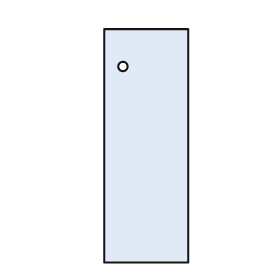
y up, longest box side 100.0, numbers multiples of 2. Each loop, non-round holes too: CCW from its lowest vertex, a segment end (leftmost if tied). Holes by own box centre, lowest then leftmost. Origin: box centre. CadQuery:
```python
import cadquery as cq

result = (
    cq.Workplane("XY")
    .moveTo(-18.0, -50.0)
    .lineTo(18.0, -50.0)
    .lineTo(18.0, 50.0)
    .lineTo(-18.0, 50.0)
    .close()
    .moveTo(-10.0, 34.0)
    .circle(2.0)
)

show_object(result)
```